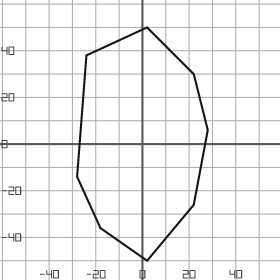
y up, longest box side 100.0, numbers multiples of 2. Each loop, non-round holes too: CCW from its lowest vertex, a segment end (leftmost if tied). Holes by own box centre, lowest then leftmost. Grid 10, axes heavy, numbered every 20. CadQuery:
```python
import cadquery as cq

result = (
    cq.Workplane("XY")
    .moveTo(2.0, -50.0)
    .lineTo(22.0, -26.0)
    .lineTo(28.0, 6.0)
    .lineTo(22.0, 30.0)
    .lineTo(2.0, 50.0)
    .lineTo(-24.0, 38.0)
    .lineTo(-28.0, -14.0)
    .lineTo(-18.0, -36.0)
    .close()
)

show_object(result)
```